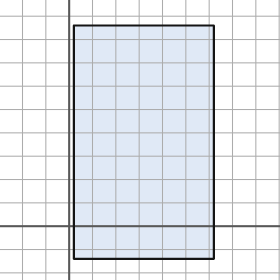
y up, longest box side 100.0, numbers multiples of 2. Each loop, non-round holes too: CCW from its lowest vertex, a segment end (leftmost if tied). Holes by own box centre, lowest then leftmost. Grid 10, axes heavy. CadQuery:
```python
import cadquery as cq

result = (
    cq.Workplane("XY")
    .moveTo(2.0, -14.0)
    .lineTo(62.0, -14.0)
    .lineTo(62.0, 86.0)
    .lineTo(2.0, 86.0)
    .close()
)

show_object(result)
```